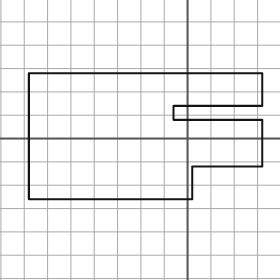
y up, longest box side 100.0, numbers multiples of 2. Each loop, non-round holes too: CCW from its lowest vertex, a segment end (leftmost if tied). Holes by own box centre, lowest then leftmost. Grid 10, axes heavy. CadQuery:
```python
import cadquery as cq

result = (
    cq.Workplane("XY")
    .moveTo(-68.0, -26.0)
    .lineTo(2.0, -26.0)
    .lineTo(2.0, -12.0)
    .lineTo(32.0, -12.0)
    .lineTo(32.0, 8.0)
    .lineTo(-6.0, 8.0)
    .lineTo(-6.0, 14.0)
    .lineTo(32.0, 14.0)
    .lineTo(32.0, 28.0)
    .lineTo(-68.0, 28.0)
    .close()
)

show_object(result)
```